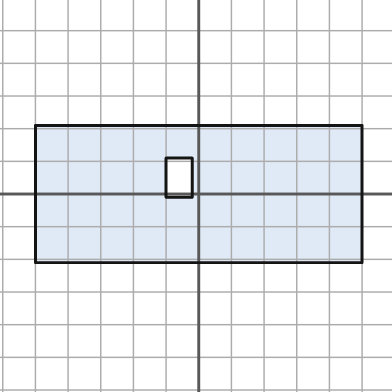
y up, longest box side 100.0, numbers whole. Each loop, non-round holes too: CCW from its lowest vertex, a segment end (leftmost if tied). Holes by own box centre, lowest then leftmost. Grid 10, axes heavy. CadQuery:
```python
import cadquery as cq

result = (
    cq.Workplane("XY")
    .moveTo(-50.0, -21.0)
    .lineTo(50.0, -21.0)
    .lineTo(50.0, 21.0)
    .lineTo(-50.0, 21.0)
    .close()
    .moveTo(-10.0, -1.0)
    .lineTo(-2.0, -1.0)
    .lineTo(-2.0, 11.0)
    .lineTo(-10.0, 11.0)
    .close()
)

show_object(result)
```